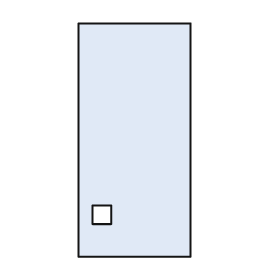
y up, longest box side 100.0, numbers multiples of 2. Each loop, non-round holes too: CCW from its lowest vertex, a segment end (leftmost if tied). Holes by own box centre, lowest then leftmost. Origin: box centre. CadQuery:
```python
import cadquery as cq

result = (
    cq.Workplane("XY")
    .moveTo(-24.0, -50.0)
    .lineTo(24.0, -50.0)
    .lineTo(24.0, 50.0)
    .lineTo(-24.0, 50.0)
    .close()
    .moveTo(-18.0, -36.0)
    .lineTo(-10.0, -36.0)
    .lineTo(-10.0, -28.0)
    .lineTo(-18.0, -28.0)
    .close()
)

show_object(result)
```